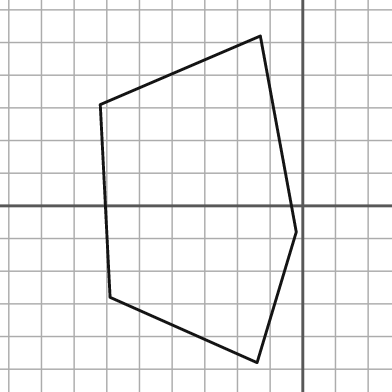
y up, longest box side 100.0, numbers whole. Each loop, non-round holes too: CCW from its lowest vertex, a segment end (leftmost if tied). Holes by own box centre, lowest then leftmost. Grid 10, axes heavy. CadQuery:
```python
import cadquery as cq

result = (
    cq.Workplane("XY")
    .moveTo(-14.0, -48.0)
    .lineTo(-2.0, -8.0)
    .lineTo(-13.0, 52.0)
    .lineTo(-62.0, 31.0)
    .lineTo(-59.0, -28.0)
    .close()
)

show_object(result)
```